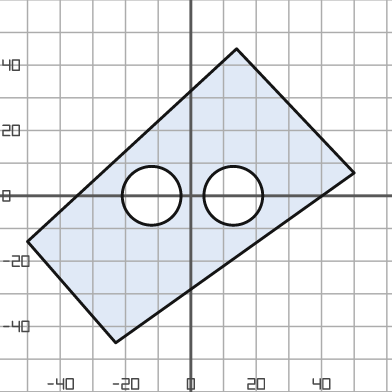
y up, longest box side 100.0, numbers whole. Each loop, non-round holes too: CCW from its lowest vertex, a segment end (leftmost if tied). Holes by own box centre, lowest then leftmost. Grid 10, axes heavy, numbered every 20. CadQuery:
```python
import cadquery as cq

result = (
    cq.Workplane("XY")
    .moveTo(-23.0, -45.0)
    .lineTo(50.0, 7.0)
    .lineTo(14.0, 45.0)
    .lineTo(-50.0, -14.0)
    .close()
    .moveTo(-12.0, 0.0)
    .circle(9.0)
    .moveTo(13.0, 0.0)
    .circle(9.0)
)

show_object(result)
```